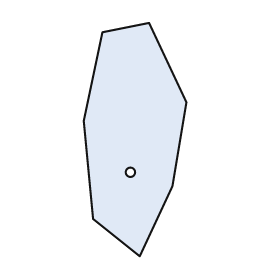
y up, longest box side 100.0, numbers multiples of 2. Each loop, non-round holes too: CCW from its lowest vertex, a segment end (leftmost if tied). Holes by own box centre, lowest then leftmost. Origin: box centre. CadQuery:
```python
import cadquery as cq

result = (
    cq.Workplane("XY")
    .moveTo(2.0, -50.0)
    .lineTo(16.0, -20.0)
    .lineTo(22.0, 16.0)
    .lineTo(6.0, 50.0)
    .lineTo(-14.0, 46.0)
    .lineTo(-22.0, 8.0)
    .lineTo(-18.0, -34.0)
    .close()
    .moveTo(-2.0, -14.0)
    .circle(2.0)
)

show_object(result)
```